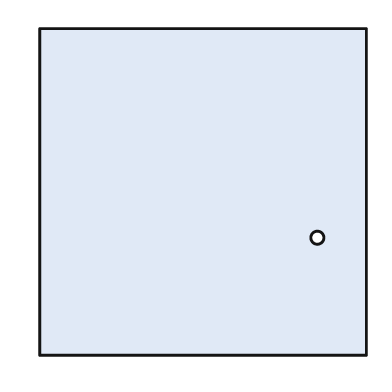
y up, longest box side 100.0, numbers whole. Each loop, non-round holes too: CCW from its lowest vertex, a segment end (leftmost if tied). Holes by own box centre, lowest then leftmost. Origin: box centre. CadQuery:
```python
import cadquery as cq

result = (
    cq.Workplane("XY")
    .moveTo(-50.0, -50.0)
    .lineTo(50.0, -50.0)
    .lineTo(50.0, 50.0)
    .lineTo(-50.0, 50.0)
    .close()
    .moveTo(35.0, -14.0)
    .circle(2.0)
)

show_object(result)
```